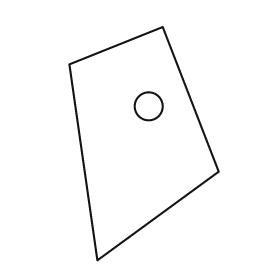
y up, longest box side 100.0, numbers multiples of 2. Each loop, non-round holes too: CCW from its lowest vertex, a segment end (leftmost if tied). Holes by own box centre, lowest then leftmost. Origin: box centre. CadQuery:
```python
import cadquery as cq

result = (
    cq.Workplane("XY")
    .moveTo(-20.0, -50.0)
    .lineTo(32.0, -12.0)
    .lineTo(8.0, 50.0)
    .lineTo(-32.0, 34.0)
    .close()
    .moveTo(2.0, 16.0)
    .circle(6.0)
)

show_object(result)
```